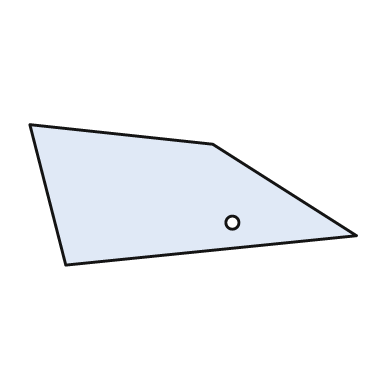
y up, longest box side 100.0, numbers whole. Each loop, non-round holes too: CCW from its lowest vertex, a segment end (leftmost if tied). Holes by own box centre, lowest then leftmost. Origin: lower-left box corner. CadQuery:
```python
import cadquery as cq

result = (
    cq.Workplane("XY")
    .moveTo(11.0, 0.0)
    .lineTo(100.0, 9.0)
    .lineTo(56.0, 37.0)
    .lineTo(0.0, 43.0)
    .close()
    .moveTo(62.0, 13.0)
    .circle(2.0)
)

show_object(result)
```